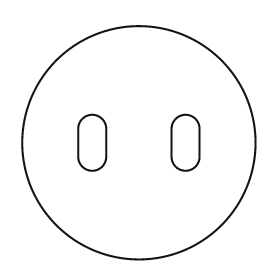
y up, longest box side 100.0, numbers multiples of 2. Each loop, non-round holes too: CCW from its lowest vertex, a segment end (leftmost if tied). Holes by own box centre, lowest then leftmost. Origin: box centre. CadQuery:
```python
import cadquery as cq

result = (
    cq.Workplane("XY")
    .moveTo(0.0, 0.0)
    .circle(50.0)
    .moveTo(-26.0, -6.0)
    .threePointArc((-20.0, -12.0), (-14.0, -6.0))
    .lineTo(-14.0, 6.0)
    .threePointArc((-20.0, 12.0), (-26.0, 6.0))
    .close()
    .moveTo(14.0, -6.0)
    .threePointArc((20.0, -12.0), (26.0, -6.0))
    .lineTo(26.0, 6.0)
    .threePointArc((20.0, 12.0), (14.0, 6.0))
    .close()
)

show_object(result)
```